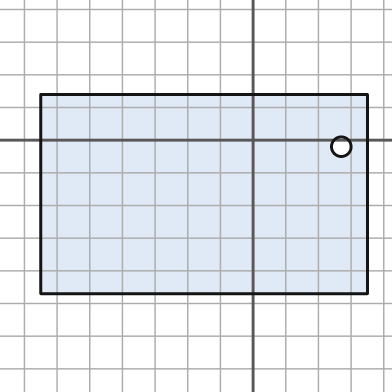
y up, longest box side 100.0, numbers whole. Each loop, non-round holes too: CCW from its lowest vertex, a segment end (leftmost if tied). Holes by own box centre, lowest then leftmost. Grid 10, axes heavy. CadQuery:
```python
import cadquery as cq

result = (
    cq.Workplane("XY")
    .moveTo(-65.0, -47.0)
    .lineTo(35.0, -47.0)
    .lineTo(35.0, 14.0)
    .lineTo(-65.0, 14.0)
    .close()
    .moveTo(27.0, -2.0)
    .circle(3.0)
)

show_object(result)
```